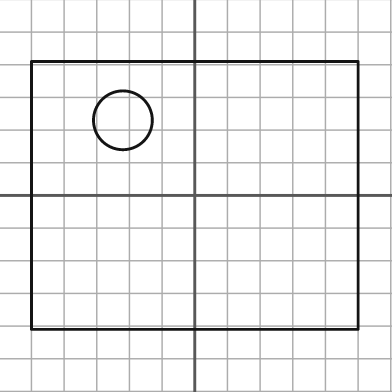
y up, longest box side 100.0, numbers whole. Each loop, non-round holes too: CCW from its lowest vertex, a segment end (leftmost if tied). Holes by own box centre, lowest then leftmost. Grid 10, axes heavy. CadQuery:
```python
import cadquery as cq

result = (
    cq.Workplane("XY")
    .moveTo(-50.0, -41.0)
    .lineTo(50.0, -41.0)
    .lineTo(50.0, 41.0)
    .lineTo(-50.0, 41.0)
    .close()
    .moveTo(-22.0, 23.0)
    .circle(9.0)
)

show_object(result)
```